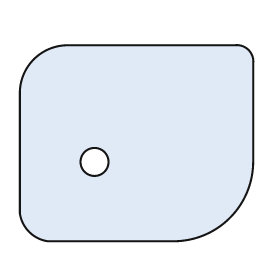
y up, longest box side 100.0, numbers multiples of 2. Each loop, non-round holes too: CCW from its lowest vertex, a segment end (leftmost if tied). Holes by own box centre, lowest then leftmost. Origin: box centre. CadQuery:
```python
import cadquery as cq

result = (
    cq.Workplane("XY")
    .moveTo(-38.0, -42.0)
    .lineTo(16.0, -42.0)
    .threePointArc((40.0, -32.0), (50.0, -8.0))
    .lineTo(50.0, 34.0)
    .threePointArc((48.0, 40.0), (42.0, 42.0))
    .lineTo(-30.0, 42.0)
    .threePointArc((-44.0, 36.0), (-50.0, 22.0))
    .lineTo(-50.0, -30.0)
    .threePointArc((-46.0, -38.0), (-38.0, -42.0))
    .close()
    .moveTo(-18.0, -8.0)
    .circle(6.0)
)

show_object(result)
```